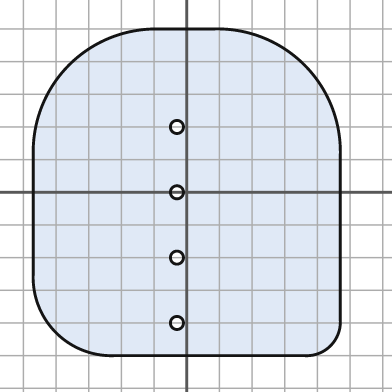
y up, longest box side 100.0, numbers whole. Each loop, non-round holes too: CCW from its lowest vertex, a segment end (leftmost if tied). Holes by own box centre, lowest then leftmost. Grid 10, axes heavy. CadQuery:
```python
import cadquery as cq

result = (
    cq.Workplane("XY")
    .moveTo(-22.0, -50.0)
    .lineTo(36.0, -50.0)
    .threePointArc((44.0, -47.0), (47.0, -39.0))
    .lineTo(47.0, 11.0)
    .threePointArc((36.0, 39.0), (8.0, 50.0))
    .lineTo(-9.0, 50.0)
    .threePointArc((-36.0, 39.0), (-47.0, 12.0))
    .lineTo(-47.0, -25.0)
    .threePointArc((-40.0, -43.0), (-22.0, -50.0))
    .close()
    .moveTo(-3.0, -40.0)
    .circle(2.0)
    .moveTo(-3.0, -20.0)
    .circle(2.0)
    .moveTo(-3.0, 0.0)
    .circle(2.0)
    .moveTo(-3.0, 20.0)
    .circle(2.0)
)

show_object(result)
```